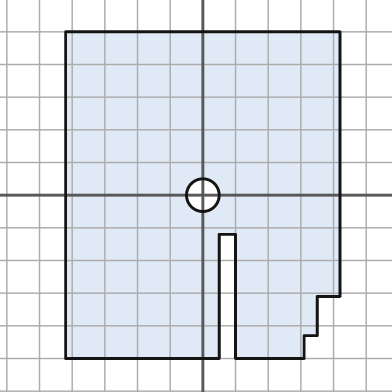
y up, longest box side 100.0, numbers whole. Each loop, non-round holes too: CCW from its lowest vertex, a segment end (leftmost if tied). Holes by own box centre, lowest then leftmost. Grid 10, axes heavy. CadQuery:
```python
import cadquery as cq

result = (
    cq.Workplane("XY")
    .moveTo(-42.0, -50.0)
    .lineTo(5.0, -50.0)
    .lineTo(5.0, -12.0)
    .lineTo(10.0, -12.0)
    .lineTo(10.0, -50.0)
    .lineTo(31.0, -50.0)
    .lineTo(31.0, -43.0)
    .lineTo(35.0, -43.0)
    .lineTo(35.0, -31.0)
    .lineTo(42.0, -31.0)
    .lineTo(42.0, 50.0)
    .lineTo(-42.0, 50.0)
    .close()
    .moveTo(0.0, 0.0)
    .circle(5.0)
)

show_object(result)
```